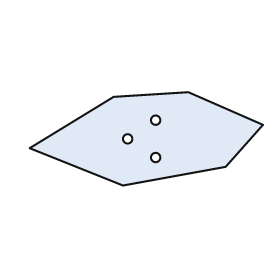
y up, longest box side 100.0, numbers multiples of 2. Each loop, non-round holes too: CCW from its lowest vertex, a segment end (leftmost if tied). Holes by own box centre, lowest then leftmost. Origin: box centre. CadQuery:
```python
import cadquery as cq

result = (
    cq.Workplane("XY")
    .moveTo(-10.0, -20.0)
    .lineTo(34.0, -12.0)
    .lineTo(50.0, 6.0)
    .lineTo(18.0, 20.0)
    .lineTo(-14.0, 18.0)
    .lineTo(-50.0, -4.0)
    .close()
    .moveTo(4.0, -8.0)
    .circle(2.0)
    .moveTo(-8.0, 0.0)
    .circle(2.0)
    .moveTo(4.0, 8.0)
    .circle(2.0)
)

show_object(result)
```